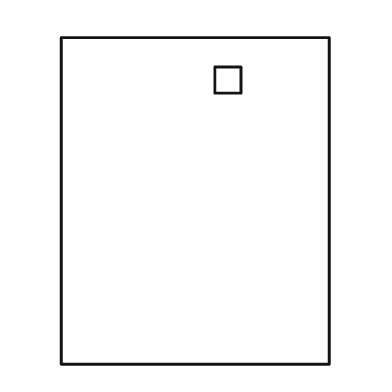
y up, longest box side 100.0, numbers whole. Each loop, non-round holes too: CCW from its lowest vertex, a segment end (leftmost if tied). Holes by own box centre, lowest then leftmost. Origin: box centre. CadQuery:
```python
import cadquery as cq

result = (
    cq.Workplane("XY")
    .moveTo(-41.0, -50.0)
    .lineTo(41.0, -50.0)
    .lineTo(41.0, 50.0)
    .lineTo(-41.0, 50.0)
    .close()
    .moveTo(6.0, 33.0)
    .lineTo(14.0, 33.0)
    .lineTo(14.0, 41.0)
    .lineTo(6.0, 41.0)
    .close()
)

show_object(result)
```